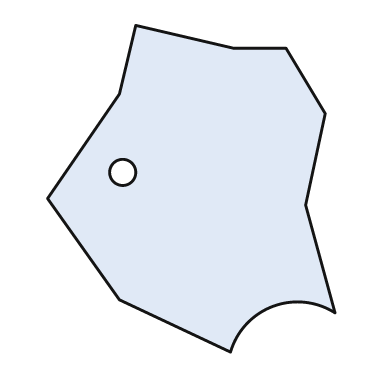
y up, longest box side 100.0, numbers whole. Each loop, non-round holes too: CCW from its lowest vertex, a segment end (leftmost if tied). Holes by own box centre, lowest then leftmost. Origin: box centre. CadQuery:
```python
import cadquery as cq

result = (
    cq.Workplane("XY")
    .moveTo(12.0, -50.0)
    .threePointArc((25.0, -36.0), (44.0, -38.0))
    .lineTo(35.0, -5.0)
    .lineTo(41.0, 23.0)
    .lineTo(29.0, 43.0)
    .lineTo(13.0, 43.0)
    .lineTo(-17.0, 50.0)
    .lineTo(-22.0, 29.0)
    .lineTo(-44.0, -3.0)
    .lineTo(-22.0, -34.0)
    .close()
    .moveTo(-21.0, 5.0)
    .circle(4.0)
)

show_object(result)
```